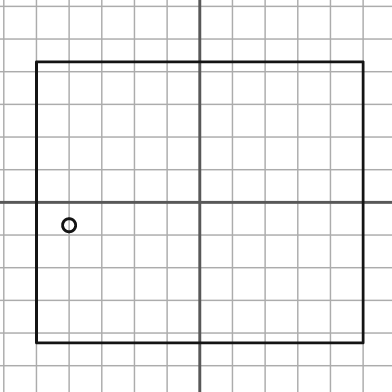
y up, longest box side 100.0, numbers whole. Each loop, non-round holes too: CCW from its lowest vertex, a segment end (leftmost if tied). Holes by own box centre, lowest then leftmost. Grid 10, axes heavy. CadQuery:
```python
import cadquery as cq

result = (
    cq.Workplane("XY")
    .moveTo(-50.0, -43.0)
    .lineTo(50.0, -43.0)
    .lineTo(50.0, 43.0)
    .lineTo(-50.0, 43.0)
    .close()
    .moveTo(-40.0, -7.0)
    .circle(2.0)
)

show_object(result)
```